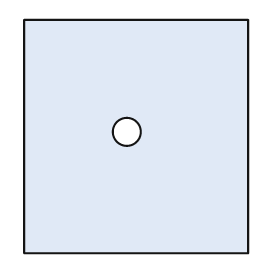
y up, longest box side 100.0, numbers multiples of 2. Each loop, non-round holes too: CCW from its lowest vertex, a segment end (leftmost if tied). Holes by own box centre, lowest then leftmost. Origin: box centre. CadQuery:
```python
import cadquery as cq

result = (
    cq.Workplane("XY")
    .moveTo(-48.0, -50.0)
    .lineTo(48.0, -50.0)
    .lineTo(48.0, 50.0)
    .lineTo(-48.0, 50.0)
    .close()
    .moveTo(-4.0, 2.0)
    .circle(6.0)
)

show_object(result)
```